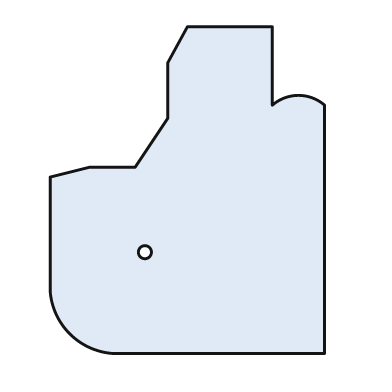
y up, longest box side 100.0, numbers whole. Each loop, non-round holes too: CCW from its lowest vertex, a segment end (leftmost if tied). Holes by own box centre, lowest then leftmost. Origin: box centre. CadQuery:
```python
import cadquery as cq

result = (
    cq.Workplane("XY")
    .moveTo(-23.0, -50.0)
    .lineTo(42.0, -50.0)
    .lineTo(42.0, 26.0)
    .threePointArc((34.0, 29.0), (26.0, 26.0))
    .lineTo(26.0, 50.0)
    .lineTo(0.0, 50.0)
    .lineTo(-6.0, 39.0)
    .lineTo(-6.0, 22.0)
    .lineTo(-16.0, 7.0)
    .lineTo(-30.0, 7.0)
    .lineTo(-42.0, 4.0)
    .lineTo(-42.0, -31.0)
    .threePointArc((-36.0, -44.0), (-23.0, -50.0))
    .close()
    .moveTo(-13.0, -19.0)
    .circle(2.0)
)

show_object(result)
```